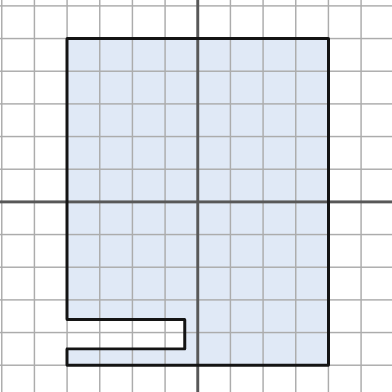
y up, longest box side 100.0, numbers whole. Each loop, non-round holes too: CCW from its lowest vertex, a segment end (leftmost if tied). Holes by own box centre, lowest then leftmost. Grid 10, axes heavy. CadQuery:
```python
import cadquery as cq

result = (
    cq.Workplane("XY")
    .moveTo(-40.0, -50.0)
    .lineTo(40.0, -50.0)
    .lineTo(40.0, 50.0)
    .lineTo(-40.0, 50.0)
    .lineTo(-40.0, -36.0)
    .lineTo(-4.0, -36.0)
    .lineTo(-4.0, -45.0)
    .lineTo(-40.0, -45.0)
    .close()
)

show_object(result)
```